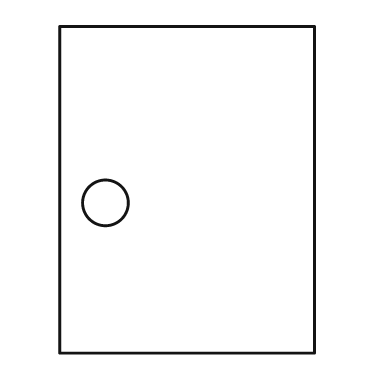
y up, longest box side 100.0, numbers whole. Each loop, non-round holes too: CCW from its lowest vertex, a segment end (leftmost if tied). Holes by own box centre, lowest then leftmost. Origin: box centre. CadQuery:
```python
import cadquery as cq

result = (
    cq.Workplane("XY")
    .moveTo(-39.0, -50.0)
    .lineTo(39.0, -50.0)
    .lineTo(39.0, 50.0)
    .lineTo(-39.0, 50.0)
    .close()
    .moveTo(-25.0, -4.0)
    .circle(7.0)
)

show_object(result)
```